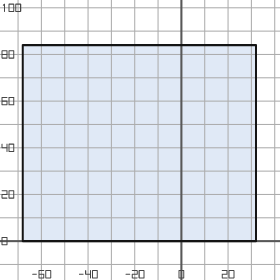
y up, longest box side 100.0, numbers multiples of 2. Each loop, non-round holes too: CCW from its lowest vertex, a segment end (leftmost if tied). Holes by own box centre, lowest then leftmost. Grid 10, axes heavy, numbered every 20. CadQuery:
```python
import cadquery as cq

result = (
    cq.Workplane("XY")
    .moveTo(-68.0, 0.0)
    .lineTo(32.0, 0.0)
    .lineTo(32.0, 84.0)
    .lineTo(-68.0, 84.0)
    .close()
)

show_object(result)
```